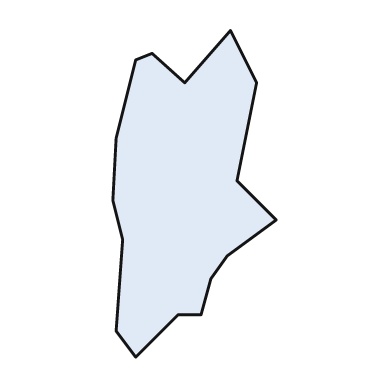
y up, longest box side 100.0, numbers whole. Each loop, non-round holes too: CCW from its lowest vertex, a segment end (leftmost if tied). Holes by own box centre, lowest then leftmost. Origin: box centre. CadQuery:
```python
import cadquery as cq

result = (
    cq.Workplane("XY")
    .moveTo(-18.0, -50.0)
    .lineTo(-5.0, -37.0)
    .lineTo(2.0, -37.0)
    .lineTo(5.0, -26.0)
    .lineTo(10.0, -19.0)
    .lineTo(25.0, -8.0)
    .lineTo(13.0, 4.0)
    .lineTo(19.0, 34.0)
    .lineTo(11.0, 50.0)
    .lineTo(-3.0, 34.0)
    .lineTo(-13.0, 43.0)
    .lineTo(-18.0, 41.0)
    .lineTo(-24.0, 17.0)
    .lineTo(-25.0, -2.0)
    .lineTo(-22.0, -14.0)
    .lineTo(-24.0, -42.0)
    .close()
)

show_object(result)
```